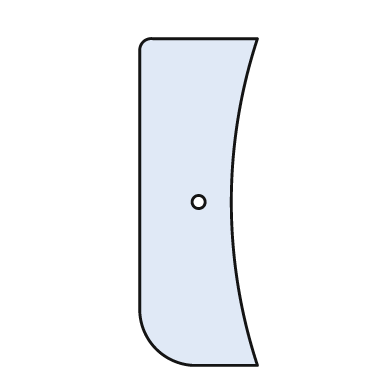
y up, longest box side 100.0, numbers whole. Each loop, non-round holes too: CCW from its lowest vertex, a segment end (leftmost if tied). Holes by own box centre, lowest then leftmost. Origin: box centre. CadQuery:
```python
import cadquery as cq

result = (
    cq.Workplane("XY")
    .moveTo(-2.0, -50.0)
    .lineTo(18.0, -50.0)
    .threePointArc((10.0, 0.0), (18.0, 50.0))
    .lineTo(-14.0, 50.0)
    .threePointArc((-17.0, 49.0), (-18.0, 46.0))
    .lineTo(-18.0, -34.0)
    .threePointArc((-13.0, -45.0), (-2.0, -50.0))
    .close()
    .moveTo(0.0, 0.0)
    .circle(2.0)
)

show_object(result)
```